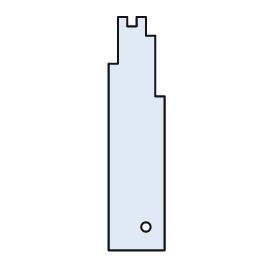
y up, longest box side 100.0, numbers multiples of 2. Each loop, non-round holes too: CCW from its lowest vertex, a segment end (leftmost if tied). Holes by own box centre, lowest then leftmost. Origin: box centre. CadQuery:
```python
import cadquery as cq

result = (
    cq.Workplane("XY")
    .moveTo(-12.0, -50.0)
    .lineTo(12.0, -50.0)
    .lineTo(12.0, 16.0)
    .lineTo(8.0, 16.0)
    .lineTo(8.0, 42.0)
    .lineTo(4.0, 42.0)
    .lineTo(4.0, 50.0)
    .lineTo(0.0, 50.0)
    .lineTo(0.0, 46.0)
    .lineTo(-4.0, 46.0)
    .lineTo(-4.0, 50.0)
    .lineTo(-8.0, 50.0)
    .lineTo(-8.0, 30.0)
    .lineTo(-12.0, 30.0)
    .close()
    .moveTo(4.0, -40.0)
    .circle(2.0)
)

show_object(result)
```